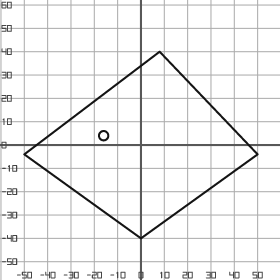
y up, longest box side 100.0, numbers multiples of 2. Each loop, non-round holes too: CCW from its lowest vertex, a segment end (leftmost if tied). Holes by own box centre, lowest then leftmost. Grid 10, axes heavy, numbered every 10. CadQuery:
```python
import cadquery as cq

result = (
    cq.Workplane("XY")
    .moveTo(0.0, -40.0)
    .lineTo(50.0, -4.0)
    .lineTo(8.0, 40.0)
    .lineTo(-50.0, -4.0)
    .close()
    .moveTo(-16.0, 4.0)
    .circle(2.0)
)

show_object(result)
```